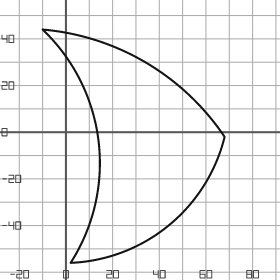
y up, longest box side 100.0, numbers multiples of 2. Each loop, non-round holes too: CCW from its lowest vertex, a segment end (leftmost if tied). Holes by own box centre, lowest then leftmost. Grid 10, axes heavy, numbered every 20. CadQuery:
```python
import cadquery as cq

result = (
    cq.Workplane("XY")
    .moveTo(2.0, -56.0)
    .threePointArc((44.0, -40.0), (68.0, -2.0))
    .threePointArc((34.0, 30.0), (-10.0, 44.0))
    .threePointArc((14.0, -4.0), (2.0, -56.0))
    .close()
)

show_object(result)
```